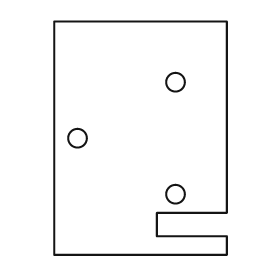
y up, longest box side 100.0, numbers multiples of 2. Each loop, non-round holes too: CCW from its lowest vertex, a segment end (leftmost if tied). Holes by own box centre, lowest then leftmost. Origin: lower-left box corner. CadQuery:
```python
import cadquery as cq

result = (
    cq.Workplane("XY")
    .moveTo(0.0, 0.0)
    .lineTo(74.0, 0.0)
    .lineTo(74.0, 8.0)
    .lineTo(44.0, 8.0)
    .lineTo(44.0, 18.0)
    .lineTo(74.0, 18.0)
    .lineTo(74.0, 100.0)
    .lineTo(0.0, 100.0)
    .close()
    .moveTo(52.0, 26.0)
    .circle(4.0)
    .moveTo(10.0, 50.0)
    .circle(4.0)
    .moveTo(52.0, 74.0)
    .circle(4.0)
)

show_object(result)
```